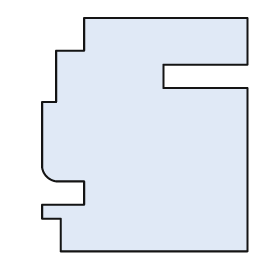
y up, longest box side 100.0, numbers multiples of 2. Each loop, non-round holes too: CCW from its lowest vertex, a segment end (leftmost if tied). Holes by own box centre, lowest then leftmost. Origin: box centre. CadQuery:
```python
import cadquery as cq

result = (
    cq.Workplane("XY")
    .moveTo(-36.0, -50.0)
    .lineTo(44.0, -50.0)
    .lineTo(44.0, 20.0)
    .lineTo(8.0, 20.0)
    .lineTo(8.0, 30.0)
    .lineTo(44.0, 30.0)
    .lineTo(44.0, 50.0)
    .lineTo(-26.0, 50.0)
    .lineTo(-26.0, 36.0)
    .lineTo(-38.0, 36.0)
    .lineTo(-38.0, 14.0)
    .lineTo(-44.0, 14.0)
    .lineTo(-44.0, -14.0)
    .threePointArc((-42.0, -18.0), (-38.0, -20.0))
    .lineTo(-26.0, -20.0)
    .lineTo(-26.0, -30.0)
    .lineTo(-44.0, -30.0)
    .lineTo(-44.0, -36.0)
    .lineTo(-36.0, -36.0)
    .close()
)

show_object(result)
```